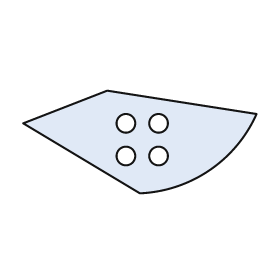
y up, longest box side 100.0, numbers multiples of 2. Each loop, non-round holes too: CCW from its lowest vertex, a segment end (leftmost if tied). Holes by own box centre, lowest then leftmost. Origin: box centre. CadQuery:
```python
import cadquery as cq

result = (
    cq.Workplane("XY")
    .moveTo(0.0, -22.0)
    .threePointArc((30.0, -12.0), (50.0, 12.0))
    .lineTo(-14.0, 22.0)
    .lineTo(-50.0, 8.0)
    .close()
    .moveTo(-6.0, -6.0)
    .circle(4.0)
    .moveTo(8.0, -6.0)
    .circle(4.0)
    .moveTo(-6.0, 8.0)
    .circle(4.0)
    .moveTo(8.0, 8.0)
    .circle(4.0)
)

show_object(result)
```